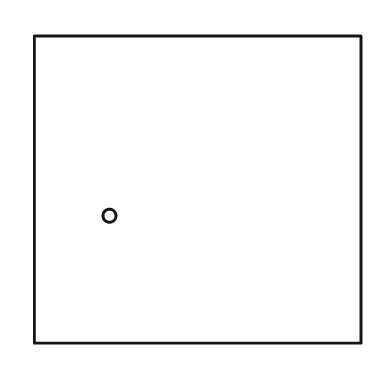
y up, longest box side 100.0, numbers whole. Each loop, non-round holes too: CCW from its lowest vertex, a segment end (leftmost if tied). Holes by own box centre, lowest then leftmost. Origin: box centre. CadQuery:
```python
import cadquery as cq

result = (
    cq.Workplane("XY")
    .moveTo(-50.0, -47.0)
    .lineTo(50.0, -47.0)
    .lineTo(50.0, 47.0)
    .lineTo(-50.0, 47.0)
    .close()
    .moveTo(-27.0, -8.0)
    .circle(2.0)
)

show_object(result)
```